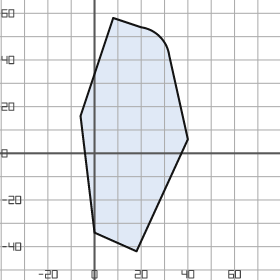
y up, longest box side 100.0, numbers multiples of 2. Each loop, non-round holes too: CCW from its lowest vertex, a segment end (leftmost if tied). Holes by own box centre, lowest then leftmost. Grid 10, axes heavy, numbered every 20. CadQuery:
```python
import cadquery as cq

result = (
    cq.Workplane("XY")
    .moveTo(18.0, -42.0)
    .lineTo(40.0, 6.0)
    .lineTo(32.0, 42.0)
    .threePointArc((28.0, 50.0), (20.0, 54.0))
    .lineTo(8.0, 58.0)
    .lineTo(-6.0, 16.0)
    .lineTo(0.0, -34.0)
    .close()
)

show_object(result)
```